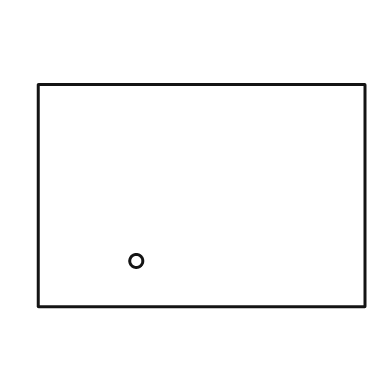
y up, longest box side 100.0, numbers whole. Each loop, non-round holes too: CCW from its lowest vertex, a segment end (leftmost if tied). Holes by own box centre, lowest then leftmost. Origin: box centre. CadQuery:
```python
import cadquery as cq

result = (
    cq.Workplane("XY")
    .moveTo(-50.0, -34.0)
    .lineTo(50.0, -34.0)
    .lineTo(50.0, 34.0)
    .lineTo(-50.0, 34.0)
    .close()
    .moveTo(-20.0, -20.0)
    .circle(2.0)
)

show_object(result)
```